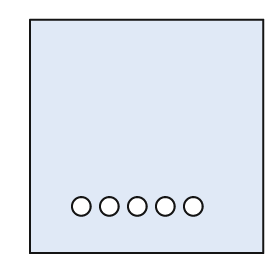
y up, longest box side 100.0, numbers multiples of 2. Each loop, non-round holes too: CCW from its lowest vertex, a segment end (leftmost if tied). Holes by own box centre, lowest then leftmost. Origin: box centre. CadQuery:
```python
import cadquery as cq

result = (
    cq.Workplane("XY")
    .moveTo(-50.0, -50.0)
    .lineTo(50.0, -50.0)
    .lineTo(50.0, 50.0)
    .lineTo(-50.0, 50.0)
    .close()
    .moveTo(-28.0, -30.0)
    .circle(4.0)
    .moveTo(-16.0, -30.0)
    .circle(4.0)
    .moveTo(-4.0, -30.0)
    .circle(4.0)
    .moveTo(8.0, -30.0)
    .circle(4.0)
    .moveTo(20.0, -30.0)
    .circle(4.0)
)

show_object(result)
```